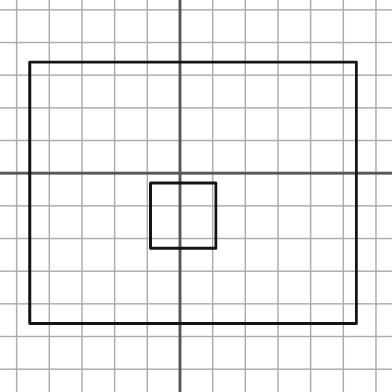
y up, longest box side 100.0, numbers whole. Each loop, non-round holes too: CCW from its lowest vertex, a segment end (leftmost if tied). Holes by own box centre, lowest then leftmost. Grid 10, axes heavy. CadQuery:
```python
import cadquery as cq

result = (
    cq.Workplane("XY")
    .moveTo(-46.0, -46.0)
    .lineTo(54.0, -46.0)
    .lineTo(54.0, 34.0)
    .lineTo(-46.0, 34.0)
    .close()
    .moveTo(-9.0, -23.0)
    .lineTo(11.0, -23.0)
    .lineTo(11.0, -3.0)
    .lineTo(-9.0, -3.0)
    .close()
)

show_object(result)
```